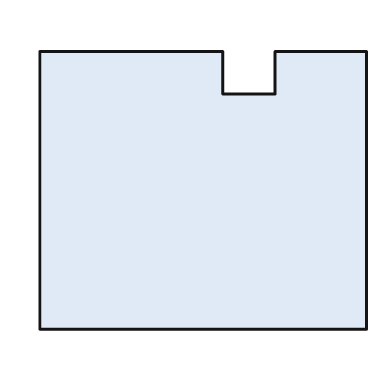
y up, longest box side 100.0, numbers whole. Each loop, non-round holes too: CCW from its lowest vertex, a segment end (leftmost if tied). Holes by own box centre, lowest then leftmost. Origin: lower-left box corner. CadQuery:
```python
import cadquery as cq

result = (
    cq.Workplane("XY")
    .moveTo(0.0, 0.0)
    .lineTo(100.0, 0.0)
    .lineTo(100.0, 85.0)
    .lineTo(72.0, 85.0)
    .lineTo(72.0, 72.0)
    .lineTo(56.0, 72.0)
    .lineTo(56.0, 85.0)
    .lineTo(0.0, 85.0)
    .close()
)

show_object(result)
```